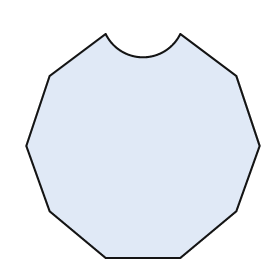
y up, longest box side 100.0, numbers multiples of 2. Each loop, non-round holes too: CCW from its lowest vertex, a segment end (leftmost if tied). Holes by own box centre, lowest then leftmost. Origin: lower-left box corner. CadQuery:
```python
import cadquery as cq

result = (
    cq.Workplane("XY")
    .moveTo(34.0, 0.0)
    .lineTo(66.0, 0.0)
    .lineTo(90.0, 20.0)
    .lineTo(100.0, 48.0)
    .lineTo(90.0, 78.0)
    .lineTo(66.0, 96.0)
    .threePointArc((50.0, 86.0), (34.0, 96.0))
    .lineTo(10.0, 78.0)
    .lineTo(0.0, 48.0)
    .lineTo(10.0, 20.0)
    .close()
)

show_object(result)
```